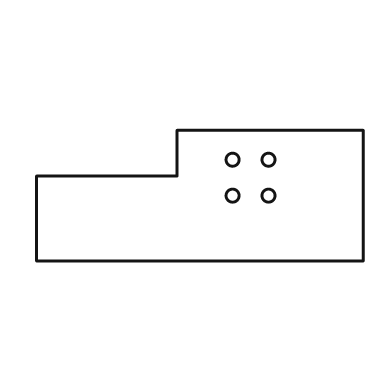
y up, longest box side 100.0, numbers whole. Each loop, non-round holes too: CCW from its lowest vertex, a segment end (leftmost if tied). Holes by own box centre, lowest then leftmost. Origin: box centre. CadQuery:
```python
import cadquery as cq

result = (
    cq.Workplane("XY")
    .moveTo(-50.0, -20.0)
    .lineTo(50.0, -20.0)
    .lineTo(50.0, 20.0)
    .lineTo(-7.0, 20.0)
    .lineTo(-7.0, 6.0)
    .lineTo(-50.0, 6.0)
    .close()
    .moveTo(10.0, 0.0)
    .circle(2.0)
    .moveTo(21.0, 0.0)
    .circle(2.0)
    .moveTo(10.0, 11.0)
    .circle(2.0)
    .moveTo(21.0, 11.0)
    .circle(2.0)
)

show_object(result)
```